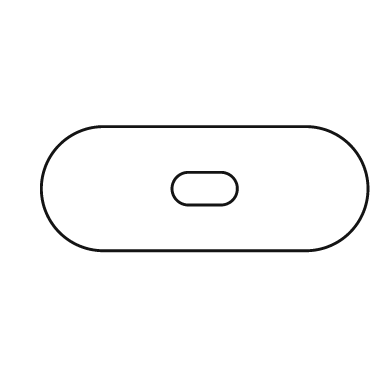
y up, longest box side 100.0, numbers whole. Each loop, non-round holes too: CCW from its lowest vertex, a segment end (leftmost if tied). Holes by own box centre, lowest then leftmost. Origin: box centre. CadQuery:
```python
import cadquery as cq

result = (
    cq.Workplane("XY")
    .moveTo(-31.0, -19.0)
    .lineTo(31.0, -19.0)
    .threePointArc((50.0, 0.0), (31.0, 19.0))
    .lineTo(-31.0, 19.0)
    .threePointArc((-50.0, 0.0), (-31.0, -19.0))
    .close()
    .moveTo(-5.0, -5.0)
    .lineTo(5.0, -5.0)
    .threePointArc((10.0, 0.0), (5.0, 5.0))
    .lineTo(-5.0, 5.0)
    .threePointArc((-10.0, 0.0), (-5.0, -5.0))
    .close()
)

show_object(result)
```